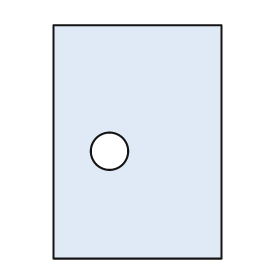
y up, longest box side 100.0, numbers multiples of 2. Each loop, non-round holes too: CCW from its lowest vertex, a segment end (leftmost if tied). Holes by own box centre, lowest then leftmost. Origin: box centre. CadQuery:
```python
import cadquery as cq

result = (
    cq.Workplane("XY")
    .moveTo(-36.0, -50.0)
    .lineTo(36.0, -50.0)
    .lineTo(36.0, 50.0)
    .lineTo(-36.0, 50.0)
    .close()
    .moveTo(-12.0, -4.0)
    .circle(8.0)
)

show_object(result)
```